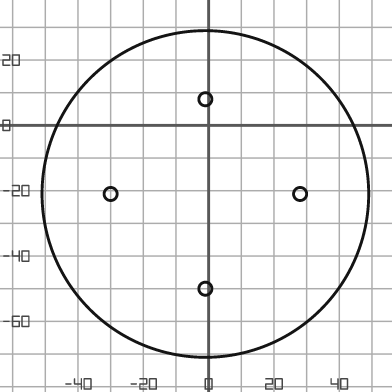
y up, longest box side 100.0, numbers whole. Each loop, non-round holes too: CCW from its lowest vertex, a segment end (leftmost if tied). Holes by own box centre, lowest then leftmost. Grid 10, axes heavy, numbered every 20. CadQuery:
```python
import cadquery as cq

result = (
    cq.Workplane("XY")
    .moveTo(-1.0, -21.0)
    .circle(50.0)
    .moveTo(-1.0, -50.0)
    .circle(2.0)
    .moveTo(-30.0, -21.0)
    .circle(2.0)
    .moveTo(28.0, -21.0)
    .circle(2.0)
    .moveTo(-1.0, 8.0)
    .circle(2.0)
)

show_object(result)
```